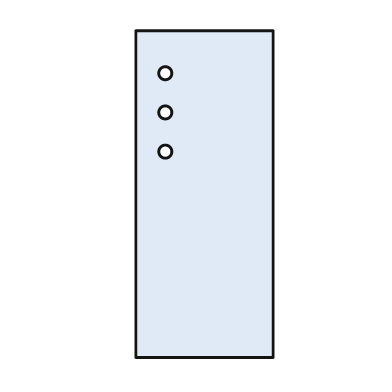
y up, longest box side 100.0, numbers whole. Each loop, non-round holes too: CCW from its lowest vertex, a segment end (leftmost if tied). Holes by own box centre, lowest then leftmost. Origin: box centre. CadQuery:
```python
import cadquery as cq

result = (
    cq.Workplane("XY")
    .moveTo(-21.0, -50.0)
    .lineTo(21.0, -50.0)
    .lineTo(21.0, 50.0)
    .lineTo(-21.0, 50.0)
    .close()
    .moveTo(-12.0, 13.0)
    .circle(2.0)
    .moveTo(-12.0, 25.0)
    .circle(2.0)
    .moveTo(-12.0, 37.0)
    .circle(2.0)
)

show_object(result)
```